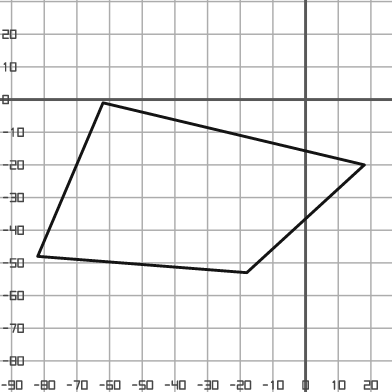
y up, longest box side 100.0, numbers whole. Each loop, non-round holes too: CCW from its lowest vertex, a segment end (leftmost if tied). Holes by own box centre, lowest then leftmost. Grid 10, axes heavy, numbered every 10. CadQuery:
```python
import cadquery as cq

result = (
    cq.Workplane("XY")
    .moveTo(-18.0, -53.0)
    .lineTo(18.0, -20.0)
    .lineTo(-62.0, -1.0)
    .lineTo(-82.0, -48.0)
    .close()
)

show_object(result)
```